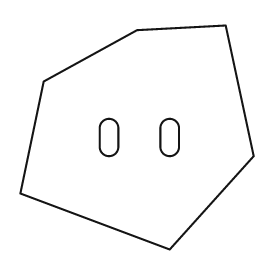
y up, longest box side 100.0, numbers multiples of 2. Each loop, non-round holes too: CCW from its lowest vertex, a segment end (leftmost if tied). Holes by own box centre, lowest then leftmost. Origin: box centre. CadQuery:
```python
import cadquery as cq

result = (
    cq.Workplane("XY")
    .moveTo(14.0, -48.0)
    .lineTo(50.0, -8.0)
    .lineTo(38.0, 48.0)
    .lineTo(0.0, 46.0)
    .lineTo(-40.0, 24.0)
    .lineTo(-50.0, -24.0)
    .close()
    .moveTo(-16.0, -4.0)
    .threePointArc((-12.0, -8.0), (-8.0, -4.0))
    .lineTo(-8.0, 4.0)
    .threePointArc((-12.0, 8.0), (-16.0, 4.0))
    .close()
    .moveTo(10.0, -4.0)
    .threePointArc((14.0, -8.0), (18.0, -4.0))
    .lineTo(18.0, 4.0)
    .threePointArc((14.0, 8.0), (10.0, 4.0))
    .close()
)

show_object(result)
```